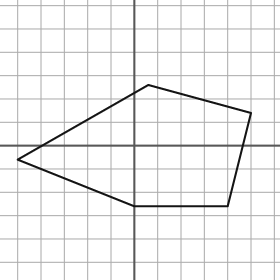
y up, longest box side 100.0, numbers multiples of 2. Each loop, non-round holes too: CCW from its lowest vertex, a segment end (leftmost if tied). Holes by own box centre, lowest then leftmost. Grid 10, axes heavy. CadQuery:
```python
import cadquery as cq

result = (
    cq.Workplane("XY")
    .moveTo(0.0, -26.0)
    .lineTo(40.0, -26.0)
    .lineTo(50.0, 14.0)
    .lineTo(6.0, 26.0)
    .lineTo(-50.0, -6.0)
    .close()
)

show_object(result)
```